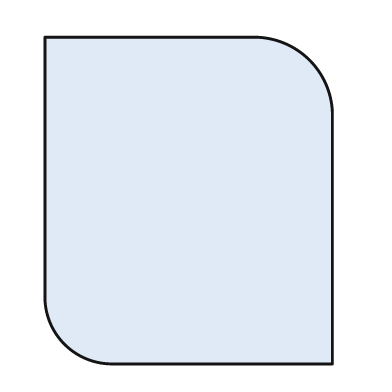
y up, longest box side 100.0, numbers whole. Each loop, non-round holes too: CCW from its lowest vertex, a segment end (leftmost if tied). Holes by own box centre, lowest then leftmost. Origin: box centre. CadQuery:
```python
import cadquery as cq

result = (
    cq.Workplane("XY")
    .moveTo(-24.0, -50.0)
    .lineTo(44.0, -50.0)
    .lineTo(44.0, 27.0)
    .threePointArc((37.0, 43.0), (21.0, 50.0))
    .lineTo(-44.0, 50.0)
    .lineTo(-44.0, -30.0)
    .threePointArc((-38.0, -44.0), (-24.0, -50.0))
    .close()
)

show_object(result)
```